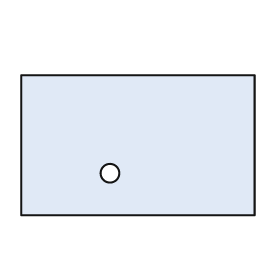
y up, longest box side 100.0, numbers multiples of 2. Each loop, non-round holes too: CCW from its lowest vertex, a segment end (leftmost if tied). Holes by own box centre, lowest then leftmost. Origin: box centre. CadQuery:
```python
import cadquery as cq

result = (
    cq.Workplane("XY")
    .moveTo(-50.0, -30.0)
    .lineTo(50.0, -30.0)
    .lineTo(50.0, 30.0)
    .lineTo(-50.0, 30.0)
    .close()
    .moveTo(-12.0, -12.0)
    .circle(4.0)
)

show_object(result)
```